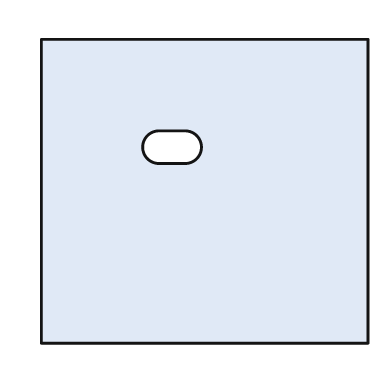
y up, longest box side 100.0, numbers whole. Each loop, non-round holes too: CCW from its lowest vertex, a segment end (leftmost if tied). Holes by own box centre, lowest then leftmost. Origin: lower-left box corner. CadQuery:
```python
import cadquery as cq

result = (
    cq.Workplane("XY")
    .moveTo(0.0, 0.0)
    .lineTo(100.0, 0.0)
    .lineTo(100.0, 93.0)
    .lineTo(0.0, 93.0)
    .close()
    .moveTo(36.0, 55.0)
    .lineTo(44.0, 55.0)
    .threePointArc((49.0, 60.0), (44.0, 65.0))
    .lineTo(36.0, 65.0)
    .threePointArc((31.0, 60.0), (36.0, 55.0))
    .close()
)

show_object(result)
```